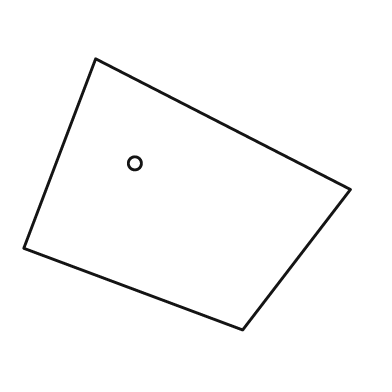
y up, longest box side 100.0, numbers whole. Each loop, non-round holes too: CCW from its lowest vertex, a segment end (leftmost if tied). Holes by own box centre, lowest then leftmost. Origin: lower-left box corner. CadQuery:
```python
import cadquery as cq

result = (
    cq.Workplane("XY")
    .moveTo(67.0, 0.0)
    .lineTo(100.0, 43.0)
    .lineTo(22.0, 83.0)
    .lineTo(0.0, 25.0)
    .close()
    .moveTo(34.0, 51.0)
    .circle(2.0)
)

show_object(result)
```